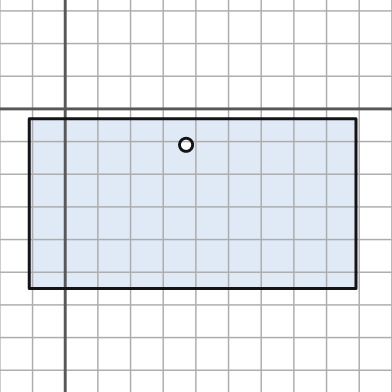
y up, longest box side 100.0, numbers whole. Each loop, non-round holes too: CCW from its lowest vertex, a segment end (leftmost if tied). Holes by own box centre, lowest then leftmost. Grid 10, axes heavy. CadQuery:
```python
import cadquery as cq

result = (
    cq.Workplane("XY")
    .moveTo(-11.0, -55.0)
    .lineTo(89.0, -55.0)
    .lineTo(89.0, -3.0)
    .lineTo(-11.0, -3.0)
    .close()
    .moveTo(37.0, -11.0)
    .circle(2.0)
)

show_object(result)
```